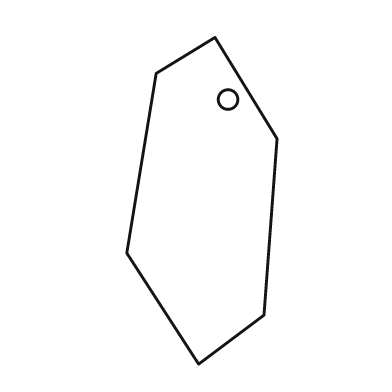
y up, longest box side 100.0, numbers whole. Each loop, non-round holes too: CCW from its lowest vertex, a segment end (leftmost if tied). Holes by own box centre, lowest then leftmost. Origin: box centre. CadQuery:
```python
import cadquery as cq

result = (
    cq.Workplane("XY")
    .moveTo(-1.0, -50.0)
    .lineTo(19.0, -35.0)
    .lineTo(23.0, 19.0)
    .lineTo(4.0, 50.0)
    .lineTo(-14.0, 39.0)
    .lineTo(-23.0, -16.0)
    .close()
    .moveTo(8.0, 31.0)
    .circle(3.0)
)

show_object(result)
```